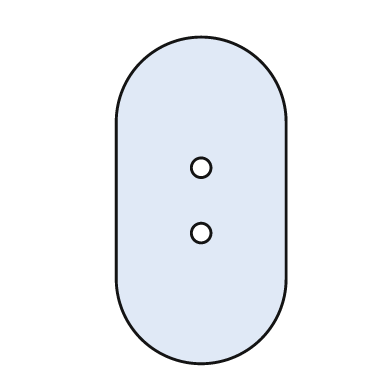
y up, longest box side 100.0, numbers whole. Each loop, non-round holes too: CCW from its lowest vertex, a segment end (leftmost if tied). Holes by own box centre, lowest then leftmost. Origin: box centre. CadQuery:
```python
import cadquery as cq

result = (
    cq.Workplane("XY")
    .moveTo(-26.0, -24.0)
    .threePointArc((0.0, -50.0), (26.0, -24.0))
    .lineTo(26.0, 24.0)
    .threePointArc((0.0, 50.0), (-26.0, 24.0))
    .close()
    .moveTo(0.0, -10.0)
    .circle(3.0)
    .moveTo(0.0, 10.0)
    .circle(3.0)
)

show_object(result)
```